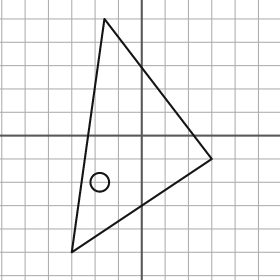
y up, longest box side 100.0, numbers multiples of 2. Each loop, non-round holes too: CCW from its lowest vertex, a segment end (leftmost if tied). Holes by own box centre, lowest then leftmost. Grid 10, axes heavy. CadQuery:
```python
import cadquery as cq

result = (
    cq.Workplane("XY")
    .moveTo(-30.0, -50.0)
    .lineTo(30.0, -10.0)
    .lineTo(-16.0, 50.0)
    .close()
    .moveTo(-18.0, -20.0)
    .circle(4.0)
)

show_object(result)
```